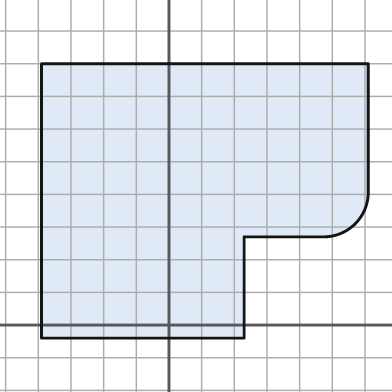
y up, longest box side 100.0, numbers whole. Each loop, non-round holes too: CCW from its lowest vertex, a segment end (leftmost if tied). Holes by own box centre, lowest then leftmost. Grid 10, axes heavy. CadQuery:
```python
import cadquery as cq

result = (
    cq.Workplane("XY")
    .moveTo(-39.0, -4.0)
    .lineTo(23.0, -4.0)
    .lineTo(23.0, 27.0)
    .lineTo(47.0, 27.0)
    .threePointArc((57.0, 31.0), (61.0, 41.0))
    .lineTo(61.0, 80.0)
    .lineTo(-39.0, 80.0)
    .close()
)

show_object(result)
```